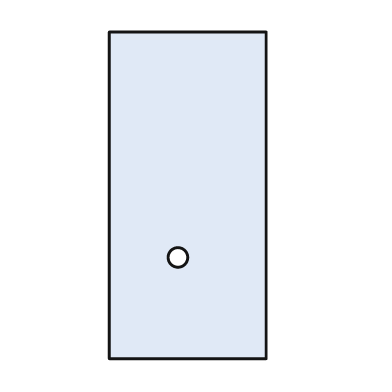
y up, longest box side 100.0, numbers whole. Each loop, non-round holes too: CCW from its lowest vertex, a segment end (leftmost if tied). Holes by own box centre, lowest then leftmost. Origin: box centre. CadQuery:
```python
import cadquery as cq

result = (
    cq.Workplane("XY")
    .moveTo(-24.0, -50.0)
    .lineTo(24.0, -50.0)
    .lineTo(24.0, 50.0)
    .lineTo(-24.0, 50.0)
    .close()
    .moveTo(-3.0, -19.0)
    .circle(3.0)
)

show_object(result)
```